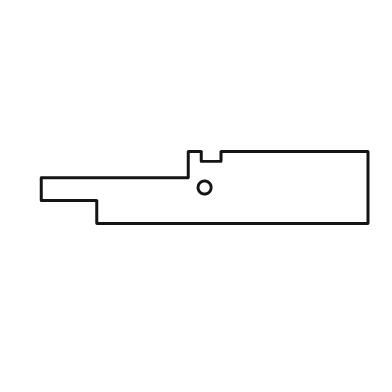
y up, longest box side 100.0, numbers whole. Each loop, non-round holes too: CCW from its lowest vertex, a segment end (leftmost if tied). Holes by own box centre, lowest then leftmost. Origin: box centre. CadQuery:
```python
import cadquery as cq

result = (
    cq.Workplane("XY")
    .moveTo(-33.0, -11.0)
    .lineTo(50.0, -11.0)
    .lineTo(50.0, 11.0)
    .lineTo(5.0, 11.0)
    .lineTo(5.0, 8.0)
    .lineTo(-1.0, 8.0)
    .lineTo(-1.0, 11.0)
    .lineTo(-5.0, 11.0)
    .lineTo(-5.0, 3.0)
    .lineTo(-50.0, 3.0)
    .lineTo(-50.0, -4.0)
    .lineTo(-33.0, -4.0)
    .close()
    .moveTo(0.0, 0.0)
    .circle(2.0)
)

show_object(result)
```